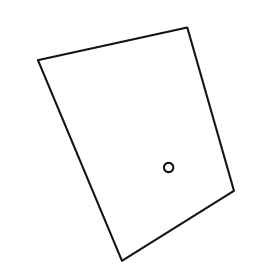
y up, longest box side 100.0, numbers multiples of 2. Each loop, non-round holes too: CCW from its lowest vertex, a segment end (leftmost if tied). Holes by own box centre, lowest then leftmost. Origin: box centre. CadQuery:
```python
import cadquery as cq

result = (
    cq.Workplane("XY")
    .moveTo(-6.0, -50.0)
    .lineTo(42.0, -20.0)
    .lineTo(22.0, 50.0)
    .lineTo(-42.0, 36.0)
    .close()
    .moveTo(14.0, -10.0)
    .circle(2.0)
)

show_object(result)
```